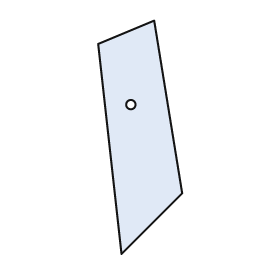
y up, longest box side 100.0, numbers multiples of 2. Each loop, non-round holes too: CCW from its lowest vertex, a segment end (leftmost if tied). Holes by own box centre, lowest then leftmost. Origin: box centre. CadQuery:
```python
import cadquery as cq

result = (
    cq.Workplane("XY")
    .moveTo(-8.0, -50.0)
    .lineTo(18.0, -24.0)
    .lineTo(6.0, 50.0)
    .lineTo(-18.0, 40.0)
    .close()
    .moveTo(-4.0, 14.0)
    .circle(2.0)
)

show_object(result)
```